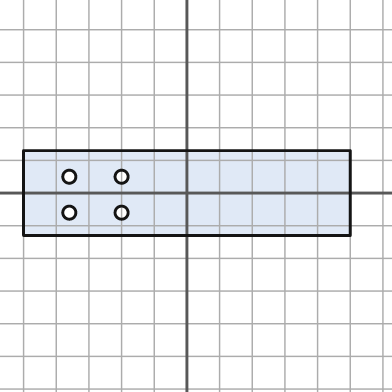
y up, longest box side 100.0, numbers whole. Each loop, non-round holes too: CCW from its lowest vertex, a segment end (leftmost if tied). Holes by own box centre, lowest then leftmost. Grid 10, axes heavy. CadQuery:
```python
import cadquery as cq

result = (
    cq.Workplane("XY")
    .moveTo(-50.0, -13.0)
    .lineTo(50.0, -13.0)
    .lineTo(50.0, 13.0)
    .lineTo(-50.0, 13.0)
    .close()
    .moveTo(-36.0, -6.0)
    .circle(2.0)
    .moveTo(-20.0, -6.0)
    .circle(2.0)
    .moveTo(-36.0, 5.0)
    .circle(2.0)
    .moveTo(-20.0, 5.0)
    .circle(2.0)
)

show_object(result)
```